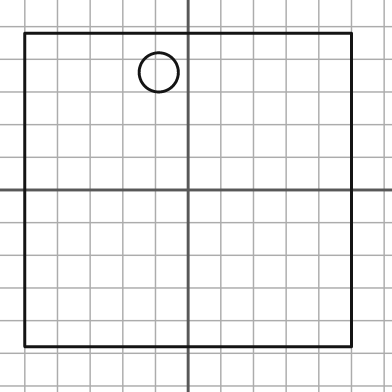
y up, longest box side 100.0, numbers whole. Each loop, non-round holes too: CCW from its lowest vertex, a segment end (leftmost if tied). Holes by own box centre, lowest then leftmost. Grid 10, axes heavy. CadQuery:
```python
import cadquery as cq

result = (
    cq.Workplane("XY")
    .moveTo(-50.0, -48.0)
    .lineTo(50.0, -48.0)
    .lineTo(50.0, 48.0)
    .lineTo(-50.0, 48.0)
    .close()
    .moveTo(-9.0, 36.0)
    .circle(6.0)
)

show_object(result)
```